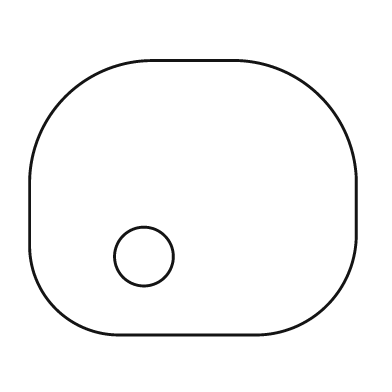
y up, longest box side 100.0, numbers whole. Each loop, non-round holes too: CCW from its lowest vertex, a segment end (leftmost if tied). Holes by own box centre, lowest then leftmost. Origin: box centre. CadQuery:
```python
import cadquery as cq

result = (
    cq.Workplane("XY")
    .moveTo(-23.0, -42.0)
    .lineTo(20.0, -42.0)
    .threePointArc((41.0, -33.0), (50.0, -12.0))
    .lineTo(50.0, 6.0)
    .threePointArc((39.0, 31.0), (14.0, 42.0))
    .lineTo(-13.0, 42.0)
    .threePointArc((-39.0, 31.0), (-50.0, 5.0))
    .lineTo(-50.0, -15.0)
    .threePointArc((-42.0, -34.0), (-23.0, -42.0))
    .close()
    .moveTo(-15.0, -18.0)
    .circle(9.0)
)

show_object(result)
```